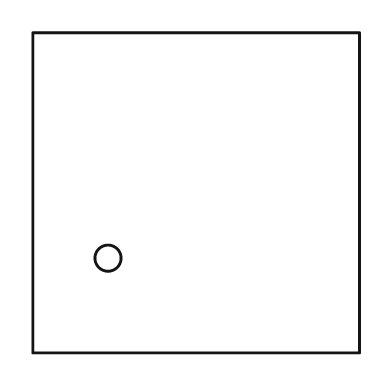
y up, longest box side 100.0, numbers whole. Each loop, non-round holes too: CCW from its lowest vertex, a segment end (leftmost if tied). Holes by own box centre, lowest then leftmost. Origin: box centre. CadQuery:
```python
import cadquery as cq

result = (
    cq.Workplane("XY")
    .moveTo(-50.0, -49.0)
    .lineTo(50.0, -49.0)
    .lineTo(50.0, 49.0)
    .lineTo(-50.0, 49.0)
    .close()
    .moveTo(-27.0, -20.0)
    .circle(4.0)
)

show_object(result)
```